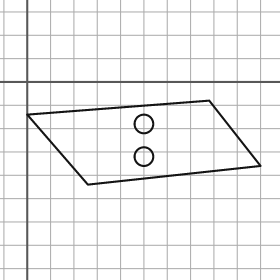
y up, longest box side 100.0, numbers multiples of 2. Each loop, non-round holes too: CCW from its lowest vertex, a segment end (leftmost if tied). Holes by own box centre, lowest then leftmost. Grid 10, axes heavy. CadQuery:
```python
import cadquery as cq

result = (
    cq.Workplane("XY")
    .moveTo(26.0, -44.0)
    .lineTo(100.0, -36.0)
    .lineTo(78.0, -8.0)
    .lineTo(0.0, -14.0)
    .close()
    .moveTo(50.0, -32.0)
    .circle(4.0)
    .moveTo(50.0, -18.0)
    .circle(4.0)
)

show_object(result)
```